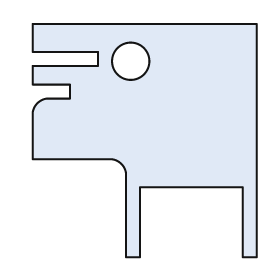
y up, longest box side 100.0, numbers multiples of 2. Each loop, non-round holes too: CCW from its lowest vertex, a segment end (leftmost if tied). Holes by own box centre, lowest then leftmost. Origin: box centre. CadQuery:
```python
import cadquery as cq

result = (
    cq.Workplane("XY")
    .moveTo(-8.0, -50.0)
    .lineTo(-2.0, -50.0)
    .lineTo(-2.0, -20.0)
    .lineTo(42.0, -20.0)
    .lineTo(42.0, -50.0)
    .lineTo(48.0, -50.0)
    .lineTo(48.0, 50.0)
    .lineTo(-48.0, 50.0)
    .lineTo(-48.0, 38.0)
    .lineTo(-20.0, 38.0)
    .lineTo(-20.0, 32.0)
    .lineTo(-48.0, 32.0)
    .lineTo(-48.0, 24.0)
    .lineTo(-32.0, 24.0)
    .lineTo(-32.0, 18.0)
    .lineTo(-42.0, 18.0)
    .threePointArc((-46.0, 16.0), (-48.0, 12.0))
    .lineTo(-48.0, -8.0)
    .lineTo(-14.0, -8.0)
    .threePointArc((-10.0, -10.0), (-8.0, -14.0))
    .close()
    .moveTo(-6.0, 34.0)
    .circle(8.0)
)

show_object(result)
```